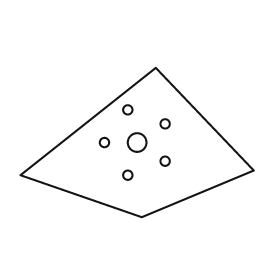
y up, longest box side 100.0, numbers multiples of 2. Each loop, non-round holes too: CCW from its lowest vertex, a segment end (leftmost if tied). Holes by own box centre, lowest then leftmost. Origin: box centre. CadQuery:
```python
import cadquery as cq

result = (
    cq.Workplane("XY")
    .moveTo(2.0, -32.0)
    .lineTo(50.0, -12.0)
    .lineTo(8.0, 32.0)
    .lineTo(-50.0, -14.0)
    .close()
    .moveTo(-4.0, -14.0)
    .circle(2.0)
    .moveTo(12.0, -8.0)
    .circle(2.0)
    .moveTo(-14.0, 0.0)
    .circle(2.0)
    .moveTo(0.0, 0.0)
    .circle(4.0)
    .moveTo(12.0, 8.0)
    .circle(2.0)
    .moveTo(-4.0, 14.0)
    .circle(2.0)
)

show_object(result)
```